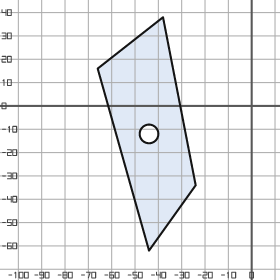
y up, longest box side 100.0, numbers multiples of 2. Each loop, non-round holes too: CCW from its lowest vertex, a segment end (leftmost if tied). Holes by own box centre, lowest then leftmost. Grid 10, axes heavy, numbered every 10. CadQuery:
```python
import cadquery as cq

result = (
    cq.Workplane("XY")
    .moveTo(-44.0, -62.0)
    .lineTo(-24.0, -34.0)
    .lineTo(-38.0, 38.0)
    .lineTo(-66.0, 16.0)
    .close()
    .moveTo(-44.0, -12.0)
    .circle(4.0)
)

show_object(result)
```